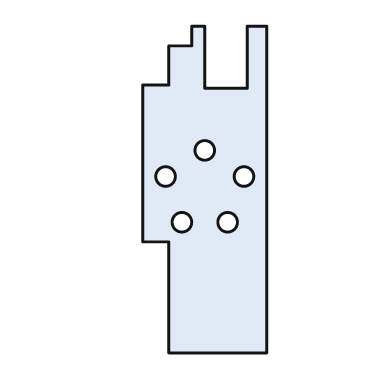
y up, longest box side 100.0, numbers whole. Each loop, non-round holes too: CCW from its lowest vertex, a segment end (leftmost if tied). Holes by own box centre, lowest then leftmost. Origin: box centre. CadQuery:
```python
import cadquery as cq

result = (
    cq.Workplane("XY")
    .moveTo(-11.0, -50.0)
    .lineTo(19.0, -50.0)
    .lineTo(19.0, 50.0)
    .lineTo(13.0, 50.0)
    .lineTo(13.0, 31.0)
    .lineTo(0.0, 31.0)
    .lineTo(0.0, 50.0)
    .lineTo(-4.0, 50.0)
    .lineTo(-4.0, 44.0)
    .lineTo(-11.0, 44.0)
    .lineTo(-11.0, 32.0)
    .lineTo(-19.0, 32.0)
    .lineTo(-19.0, -16.0)
    .lineTo(-11.0, -16.0)
    .close()
    .moveTo(-7.0, -10.0)
    .circle(3.0)
    .moveTo(7.0, -10.0)
    .circle(3.0)
    .moveTo(-12.0, 4.0)
    .circle(3.0)
    .moveTo(12.0, 4.0)
    .circle(3.0)
    .moveTo(0.0, 12.0)
    .circle(3.0)
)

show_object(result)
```